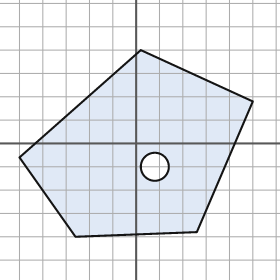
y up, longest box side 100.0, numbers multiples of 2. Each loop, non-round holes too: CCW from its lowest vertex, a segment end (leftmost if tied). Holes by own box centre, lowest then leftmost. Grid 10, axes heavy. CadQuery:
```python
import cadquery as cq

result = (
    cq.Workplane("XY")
    .moveTo(-26.0, -40.0)
    .lineTo(26.0, -38.0)
    .lineTo(50.0, 18.0)
    .lineTo(2.0, 40.0)
    .lineTo(-50.0, -6.0)
    .close()
    .moveTo(8.0, -10.0)
    .circle(6.0)
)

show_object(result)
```